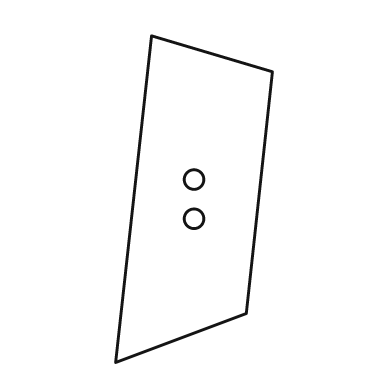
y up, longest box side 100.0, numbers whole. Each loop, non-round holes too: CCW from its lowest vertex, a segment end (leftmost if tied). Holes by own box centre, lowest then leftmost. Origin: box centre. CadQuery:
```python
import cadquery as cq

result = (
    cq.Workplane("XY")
    .moveTo(-24.0, -50.0)
    .lineTo(16.0, -35.0)
    .lineTo(24.0, 39.0)
    .lineTo(-13.0, 50.0)
    .close()
    .moveTo(0.0, -6.0)
    .circle(3.0)
    .moveTo(0.0, 6.0)
    .circle(3.0)
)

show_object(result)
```